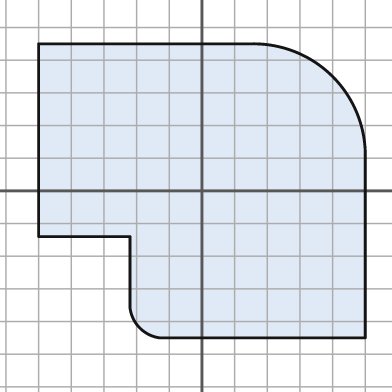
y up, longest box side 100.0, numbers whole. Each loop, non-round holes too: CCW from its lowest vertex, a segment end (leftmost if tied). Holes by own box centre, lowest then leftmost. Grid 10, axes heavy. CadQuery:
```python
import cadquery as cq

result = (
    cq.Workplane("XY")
    .moveTo(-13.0, -45.0)
    .lineTo(50.0, -45.0)
    .lineTo(50.0, 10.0)
    .threePointArc((40.0, 35.0), (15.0, 45.0))
    .lineTo(-50.0, 45.0)
    .lineTo(-50.0, -14.0)
    .lineTo(-22.0, -14.0)
    .lineTo(-22.0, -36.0)
    .threePointArc((-19.0, -42.0), (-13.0, -45.0))
    .close()
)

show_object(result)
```